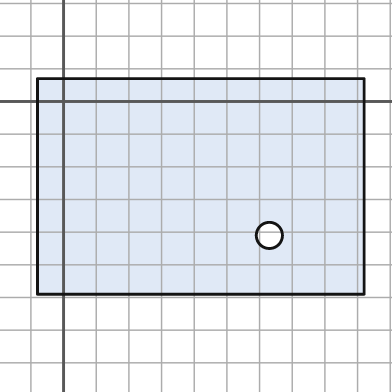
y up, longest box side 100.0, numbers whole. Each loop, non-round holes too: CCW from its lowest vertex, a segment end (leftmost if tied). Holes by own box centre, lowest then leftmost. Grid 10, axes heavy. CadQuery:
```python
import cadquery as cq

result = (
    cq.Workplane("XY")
    .moveTo(-8.0, -59.0)
    .lineTo(92.0, -59.0)
    .lineTo(92.0, 7.0)
    .lineTo(-8.0, 7.0)
    .close()
    .moveTo(63.0, -41.0)
    .circle(4.0)
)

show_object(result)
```